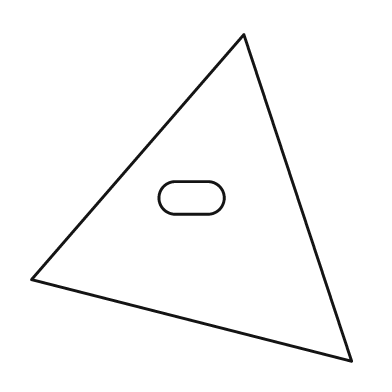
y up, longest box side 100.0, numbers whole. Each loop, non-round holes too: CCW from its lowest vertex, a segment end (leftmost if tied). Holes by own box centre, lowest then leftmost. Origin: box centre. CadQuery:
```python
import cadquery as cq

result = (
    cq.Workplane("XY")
    .moveTo(49.0, -50.0)
    .lineTo(16.0, 50.0)
    .lineTo(-49.0, -25.0)
    .close()
    .moveTo(-5.0, -5.0)
    .lineTo(5.0, -5.0)
    .threePointArc((10.0, 0.0), (5.0, 5.0))
    .lineTo(-5.0, 5.0)
    .threePointArc((-10.0, 0.0), (-5.0, -5.0))
    .close()
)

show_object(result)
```